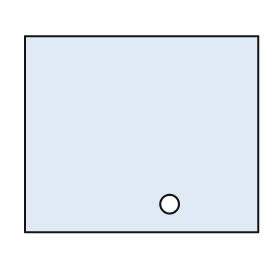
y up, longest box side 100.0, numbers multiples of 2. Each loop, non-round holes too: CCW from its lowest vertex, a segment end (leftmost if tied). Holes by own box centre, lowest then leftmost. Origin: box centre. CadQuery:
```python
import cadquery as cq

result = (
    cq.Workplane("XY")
    .moveTo(-50.0, -42.0)
    .lineTo(50.0, -42.0)
    .lineTo(50.0, 42.0)
    .lineTo(-50.0, 42.0)
    .close()
    .moveTo(12.0, -30.0)
    .circle(4.0)
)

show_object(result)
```